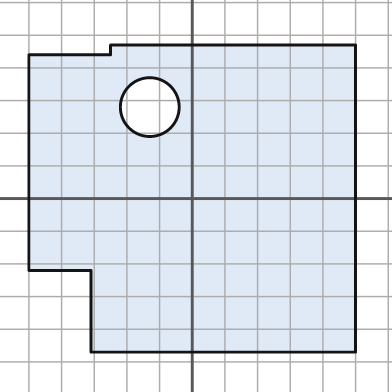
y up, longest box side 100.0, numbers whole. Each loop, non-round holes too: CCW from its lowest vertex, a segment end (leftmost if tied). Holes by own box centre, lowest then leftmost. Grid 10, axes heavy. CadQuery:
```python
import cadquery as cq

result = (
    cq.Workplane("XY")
    .moveTo(-31.0, -47.0)
    .lineTo(50.0, -47.0)
    .lineTo(50.0, 47.0)
    .lineTo(-25.0, 47.0)
    .lineTo(-25.0, 44.0)
    .lineTo(-50.0, 44.0)
    .lineTo(-50.0, -22.0)
    .lineTo(-31.0, -22.0)
    .close()
    .moveTo(-13.0, 28.0)
    .circle(9.0)
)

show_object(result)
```